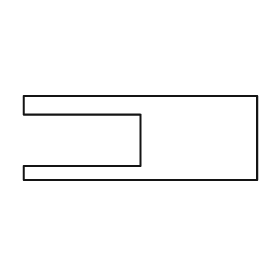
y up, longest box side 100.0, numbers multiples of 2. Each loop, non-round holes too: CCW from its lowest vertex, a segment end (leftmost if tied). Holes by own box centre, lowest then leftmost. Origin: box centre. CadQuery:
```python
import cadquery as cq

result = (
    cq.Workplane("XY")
    .moveTo(-50.0, -18.0)
    .lineTo(50.0, -18.0)
    .lineTo(50.0, 18.0)
    .lineTo(-50.0, 18.0)
    .lineTo(-50.0, 10.0)
    .lineTo(0.0, 10.0)
    .lineTo(0.0, -12.0)
    .lineTo(-50.0, -12.0)
    .close()
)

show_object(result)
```